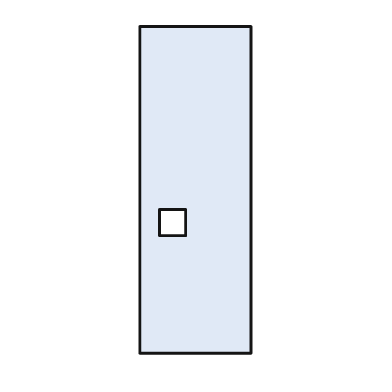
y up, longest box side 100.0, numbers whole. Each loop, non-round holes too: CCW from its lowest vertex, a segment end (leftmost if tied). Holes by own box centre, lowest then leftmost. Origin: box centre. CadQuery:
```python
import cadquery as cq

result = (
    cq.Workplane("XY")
    .moveTo(-17.0, -50.0)
    .lineTo(17.0, -50.0)
    .lineTo(17.0, 50.0)
    .lineTo(-17.0, 50.0)
    .close()
    .moveTo(-11.0, -14.0)
    .lineTo(-3.0, -14.0)
    .lineTo(-3.0, -6.0)
    .lineTo(-11.0, -6.0)
    .close()
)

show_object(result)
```